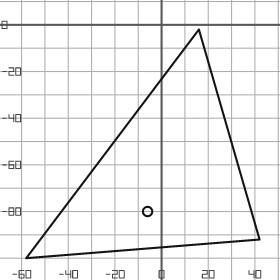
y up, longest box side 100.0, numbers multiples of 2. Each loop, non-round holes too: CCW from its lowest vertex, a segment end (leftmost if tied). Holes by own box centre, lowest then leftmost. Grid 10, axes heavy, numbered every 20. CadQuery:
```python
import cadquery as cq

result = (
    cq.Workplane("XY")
    .moveTo(-58.0, -100.0)
    .lineTo(42.0, -92.0)
    .lineTo(16.0, -2.0)
    .close()
    .moveTo(-6.0, -80.0)
    .circle(2.0)
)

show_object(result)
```